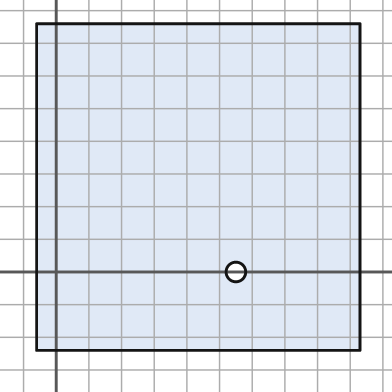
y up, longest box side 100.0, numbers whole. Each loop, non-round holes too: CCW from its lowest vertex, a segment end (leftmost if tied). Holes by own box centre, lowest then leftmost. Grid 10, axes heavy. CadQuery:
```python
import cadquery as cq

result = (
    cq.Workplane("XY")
    .moveTo(-6.0, -24.0)
    .lineTo(93.0, -24.0)
    .lineTo(93.0, 76.0)
    .lineTo(-6.0, 76.0)
    .close()
    .moveTo(55.0, 0.0)
    .circle(3.0)
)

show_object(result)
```